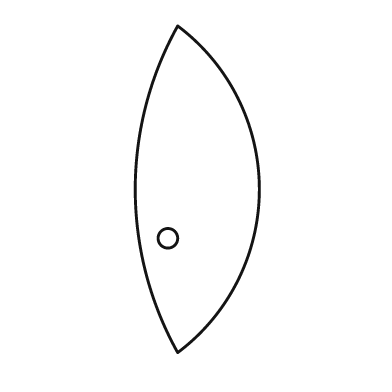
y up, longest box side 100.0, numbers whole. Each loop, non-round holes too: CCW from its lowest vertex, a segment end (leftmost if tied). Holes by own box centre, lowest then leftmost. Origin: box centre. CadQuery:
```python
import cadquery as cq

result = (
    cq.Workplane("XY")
    .moveTo(-6.0, -50.0)
    .threePointArc((19.0, 0.0), (-6.0, 50.0))
    .threePointArc((-19.0, 0.0), (-6.0, -50.0))
    .close()
    .moveTo(-9.0, -15.0)
    .circle(3.0)
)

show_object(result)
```